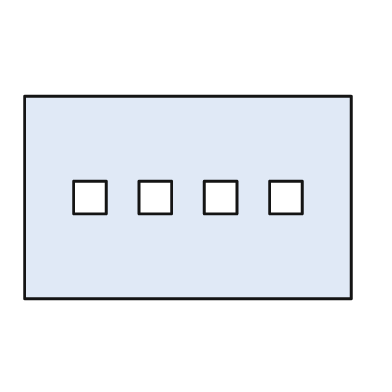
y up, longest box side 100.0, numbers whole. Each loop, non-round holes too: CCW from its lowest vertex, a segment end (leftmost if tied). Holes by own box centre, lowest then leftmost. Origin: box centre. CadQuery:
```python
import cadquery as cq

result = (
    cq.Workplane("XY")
    .moveTo(-50.0, -31.0)
    .lineTo(50.0, -31.0)
    .lineTo(50.0, 31.0)
    .lineTo(-50.0, 31.0)
    .close()
    .moveTo(-35.0, -5.0)
    .lineTo(-25.0, -5.0)
    .lineTo(-25.0, 5.0)
    .lineTo(-35.0, 5.0)
    .close()
    .moveTo(-15.0, -5.0)
    .lineTo(-5.0, -5.0)
    .lineTo(-5.0, 5.0)
    .lineTo(-15.0, 5.0)
    .close()
    .moveTo(5.0, -5.0)
    .lineTo(15.0, -5.0)
    .lineTo(15.0, 5.0)
    .lineTo(5.0, 5.0)
    .close()
    .moveTo(25.0, -5.0)
    .lineTo(35.0, -5.0)
    .lineTo(35.0, 5.0)
    .lineTo(25.0, 5.0)
    .close()
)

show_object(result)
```